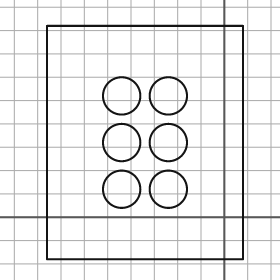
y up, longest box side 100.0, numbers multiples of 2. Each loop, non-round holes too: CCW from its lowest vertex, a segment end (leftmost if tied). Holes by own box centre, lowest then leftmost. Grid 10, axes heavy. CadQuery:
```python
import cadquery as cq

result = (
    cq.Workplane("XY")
    .moveTo(-76.0, -18.0)
    .lineTo(8.0, -18.0)
    .lineTo(8.0, 82.0)
    .lineTo(-76.0, 82.0)
    .close()
    .moveTo(-44.0, 12.0)
    .circle(8.0)
    .moveTo(-24.0, 12.0)
    .circle(8.0)
    .moveTo(-44.0, 32.0)
    .circle(8.0)
    .moveTo(-24.0, 32.0)
    .circle(8.0)
    .moveTo(-44.0, 52.0)
    .circle(8.0)
    .moveTo(-24.0, 52.0)
    .circle(8.0)
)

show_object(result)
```